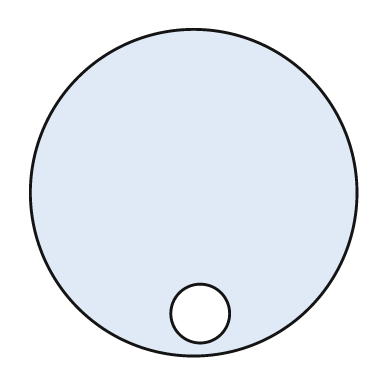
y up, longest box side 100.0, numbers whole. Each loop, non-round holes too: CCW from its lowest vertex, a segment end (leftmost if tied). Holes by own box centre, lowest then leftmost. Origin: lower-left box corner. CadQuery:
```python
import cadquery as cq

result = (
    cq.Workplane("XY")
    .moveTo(50.0, 50.0)
    .circle(50.0)
    .moveTo(52.0, 13.0)
    .circle(9.0)
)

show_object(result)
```